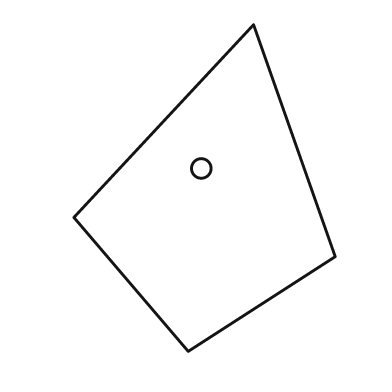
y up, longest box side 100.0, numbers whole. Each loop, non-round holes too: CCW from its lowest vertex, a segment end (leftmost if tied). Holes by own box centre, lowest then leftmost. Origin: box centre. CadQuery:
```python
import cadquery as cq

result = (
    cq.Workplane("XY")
    .moveTo(-5.0, -50.0)
    .lineTo(40.0, -21.0)
    .lineTo(15.0, 50.0)
    .lineTo(-40.0, -9.0)
    .close()
    .moveTo(-1.0, 6.0)
    .circle(3.0)
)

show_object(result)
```